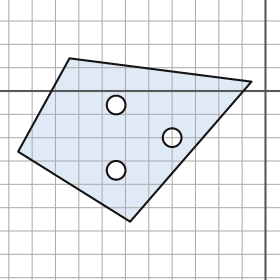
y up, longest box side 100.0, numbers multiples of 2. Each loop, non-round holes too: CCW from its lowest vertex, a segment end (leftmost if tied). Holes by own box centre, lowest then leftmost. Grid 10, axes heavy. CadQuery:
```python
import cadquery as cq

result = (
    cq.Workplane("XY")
    .moveTo(-58.0, -56.0)
    .lineTo(-6.0, 4.0)
    .lineTo(-84.0, 14.0)
    .lineTo(-106.0, -26.0)
    .close()
    .moveTo(-64.0, -34.0)
    .circle(4.0)
    .moveTo(-40.0, -20.0)
    .circle(4.0)
    .moveTo(-64.0, -6.0)
    .circle(4.0)
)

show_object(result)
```